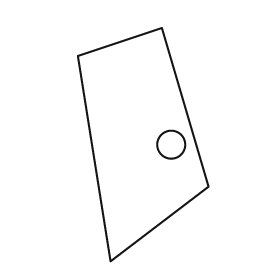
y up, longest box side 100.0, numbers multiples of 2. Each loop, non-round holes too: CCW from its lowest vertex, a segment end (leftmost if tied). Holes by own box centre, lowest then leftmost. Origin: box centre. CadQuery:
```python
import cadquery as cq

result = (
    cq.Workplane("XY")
    .moveTo(-14.0, -50.0)
    .lineTo(28.0, -18.0)
    .lineTo(8.0, 50.0)
    .lineTo(-28.0, 38.0)
    .close()
    .moveTo(12.0, 0.0)
    .circle(6.0)
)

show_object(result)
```